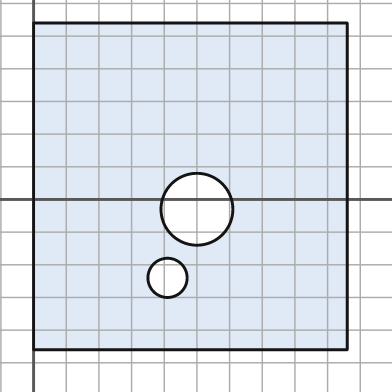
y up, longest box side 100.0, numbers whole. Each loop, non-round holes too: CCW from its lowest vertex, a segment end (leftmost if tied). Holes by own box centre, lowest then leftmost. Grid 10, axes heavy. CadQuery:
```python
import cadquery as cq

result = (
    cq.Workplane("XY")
    .moveTo(0.0, -46.0)
    .lineTo(96.0, -46.0)
    .lineTo(96.0, 54.0)
    .lineTo(0.0, 54.0)
    .close()
    .moveTo(41.0, -24.0)
    .circle(6.0)
    .moveTo(50.0, -3.0)
    .circle(11.0)
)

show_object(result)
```